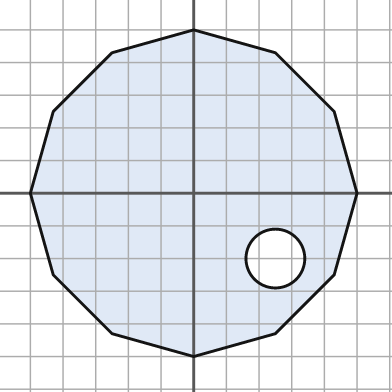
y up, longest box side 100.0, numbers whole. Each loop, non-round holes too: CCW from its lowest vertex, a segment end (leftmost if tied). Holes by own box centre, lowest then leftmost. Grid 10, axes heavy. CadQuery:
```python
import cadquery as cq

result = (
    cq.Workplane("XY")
    .moveTo(0.0, -50.0)
    .lineTo(25.0, -43.0)
    .lineTo(43.0, -25.0)
    .lineTo(50.0, 0.0)
    .lineTo(43.0, 25.0)
    .lineTo(25.0, 43.0)
    .lineTo(0.0, 50.0)
    .lineTo(-25.0, 43.0)
    .lineTo(-43.0, 25.0)
    .lineTo(-50.0, 0.0)
    .lineTo(-43.0, -25.0)
    .lineTo(-25.0, -43.0)
    .close()
    .moveTo(25.0, -20.0)
    .circle(9.0)
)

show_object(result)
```